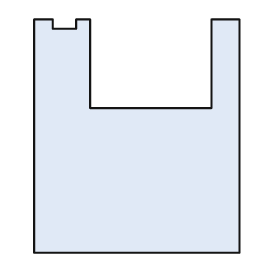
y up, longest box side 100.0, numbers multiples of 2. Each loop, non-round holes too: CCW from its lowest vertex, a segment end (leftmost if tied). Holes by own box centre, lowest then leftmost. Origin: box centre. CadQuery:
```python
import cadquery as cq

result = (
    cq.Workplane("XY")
    .moveTo(-44.0, -50.0)
    .lineTo(44.0, -50.0)
    .lineTo(44.0, 50.0)
    .lineTo(32.0, 50.0)
    .lineTo(32.0, 12.0)
    .lineTo(-20.0, 12.0)
    .lineTo(-20.0, 50.0)
    .lineTo(-26.0, 50.0)
    .lineTo(-26.0, 46.0)
    .lineTo(-36.0, 46.0)
    .lineTo(-36.0, 50.0)
    .lineTo(-44.0, 50.0)
    .close()
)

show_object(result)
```